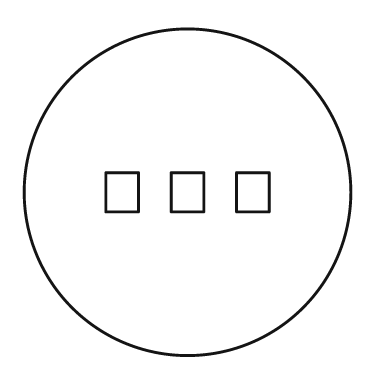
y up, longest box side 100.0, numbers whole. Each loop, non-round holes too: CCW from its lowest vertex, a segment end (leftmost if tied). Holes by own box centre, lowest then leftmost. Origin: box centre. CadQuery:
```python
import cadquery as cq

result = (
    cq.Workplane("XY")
    .moveTo(0.0, 0.0)
    .circle(50.0)
    .moveTo(-25.0, -6.0)
    .lineTo(-15.0, -6.0)
    .lineTo(-15.0, 6.0)
    .lineTo(-25.0, 6.0)
    .close()
    .moveTo(-5.0, -6.0)
    .lineTo(5.0, -6.0)
    .lineTo(5.0, 6.0)
    .lineTo(-5.0, 6.0)
    .close()
    .moveTo(15.0, -6.0)
    .lineTo(25.0, -6.0)
    .lineTo(25.0, 6.0)
    .lineTo(15.0, 6.0)
    .close()
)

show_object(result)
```